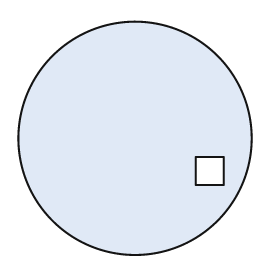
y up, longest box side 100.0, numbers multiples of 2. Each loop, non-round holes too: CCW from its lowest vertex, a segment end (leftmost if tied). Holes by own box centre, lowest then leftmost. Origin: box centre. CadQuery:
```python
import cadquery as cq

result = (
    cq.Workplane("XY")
    .moveTo(0.0, 0.0)
    .circle(50.0)
    .moveTo(26.0, -20.0)
    .lineTo(38.0, -20.0)
    .lineTo(38.0, -8.0)
    .lineTo(26.0, -8.0)
    .close()
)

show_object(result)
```